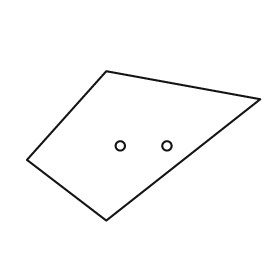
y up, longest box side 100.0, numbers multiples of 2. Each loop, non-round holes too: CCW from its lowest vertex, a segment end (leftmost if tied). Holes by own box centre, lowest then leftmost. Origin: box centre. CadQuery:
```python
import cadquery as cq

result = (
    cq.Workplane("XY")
    .moveTo(-16.0, -32.0)
    .lineTo(50.0, 20.0)
    .lineTo(-16.0, 32.0)
    .lineTo(-50.0, -6.0)
    .close()
    .moveTo(-10.0, 0.0)
    .circle(2.0)
    .moveTo(10.0, 0.0)
    .circle(2.0)
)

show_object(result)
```